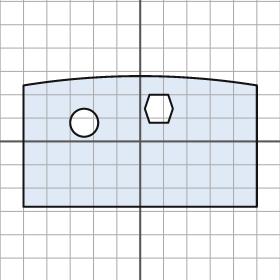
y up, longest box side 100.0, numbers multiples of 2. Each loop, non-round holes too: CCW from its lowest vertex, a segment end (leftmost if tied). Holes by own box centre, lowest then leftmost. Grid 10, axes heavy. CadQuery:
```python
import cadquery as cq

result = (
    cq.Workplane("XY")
    .moveTo(-50.0, -28.0)
    .lineTo(50.0, -28.0)
    .lineTo(50.0, 24.0)
    .threePointArc((0.0, 28.0), (-50.0, 24.0))
    .close()
    .moveTo(-24.0, 8.0)
    .circle(6.0)
    .moveTo(4.0, 8.0)
    .lineTo(12.0, 8.0)
    .lineTo(14.0, 14.0)
    .lineTo(12.0, 20.0)
    .lineTo(4.0, 20.0)
    .lineTo(2.0, 14.0)
    .close()
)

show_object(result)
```